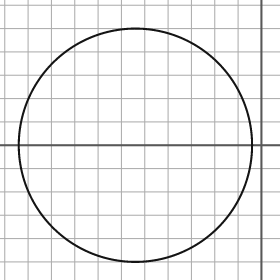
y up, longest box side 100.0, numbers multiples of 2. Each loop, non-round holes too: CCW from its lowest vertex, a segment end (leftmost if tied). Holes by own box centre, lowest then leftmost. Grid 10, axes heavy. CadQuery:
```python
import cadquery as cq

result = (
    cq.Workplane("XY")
    .moveTo(-54.0, 0.0)
    .circle(50.0)
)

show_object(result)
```